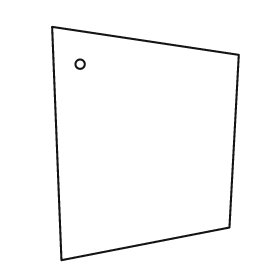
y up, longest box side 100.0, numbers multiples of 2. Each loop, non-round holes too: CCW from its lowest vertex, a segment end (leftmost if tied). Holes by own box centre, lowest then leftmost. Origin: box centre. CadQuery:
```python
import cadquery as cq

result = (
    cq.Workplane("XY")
    .moveTo(-36.0, -50.0)
    .lineTo(36.0, -36.0)
    .lineTo(40.0, 38.0)
    .lineTo(-40.0, 50.0)
    .close()
    .moveTo(-28.0, 34.0)
    .circle(2.0)
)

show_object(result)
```